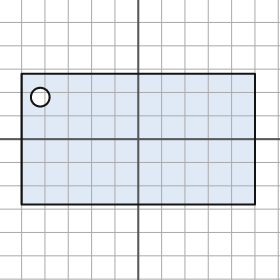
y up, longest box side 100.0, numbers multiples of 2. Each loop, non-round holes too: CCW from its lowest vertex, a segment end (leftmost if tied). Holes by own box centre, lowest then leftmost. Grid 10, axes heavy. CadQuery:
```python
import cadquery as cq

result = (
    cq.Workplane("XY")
    .moveTo(-50.0, -28.0)
    .lineTo(50.0, -28.0)
    .lineTo(50.0, 28.0)
    .lineTo(-50.0, 28.0)
    .close()
    .moveTo(-42.0, 18.0)
    .circle(4.0)
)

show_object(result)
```